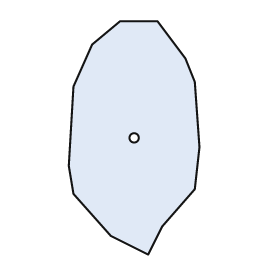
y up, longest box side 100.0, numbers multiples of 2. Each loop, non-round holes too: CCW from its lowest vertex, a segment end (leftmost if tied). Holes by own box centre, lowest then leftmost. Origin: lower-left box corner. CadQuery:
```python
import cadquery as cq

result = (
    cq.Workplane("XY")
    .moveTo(34.0, 0.0)
    .lineTo(40.0, 12.0)
    .lineTo(54.0, 28.0)
    .lineTo(56.0, 46.0)
    .lineTo(54.0, 74.0)
    .lineTo(50.0, 84.0)
    .lineTo(38.0, 100.0)
    .lineTo(22.0, 100.0)
    .lineTo(10.0, 90.0)
    .lineTo(2.0, 72.0)
    .lineTo(0.0, 38.0)
    .lineTo(2.0, 26.0)
    .lineTo(18.0, 8.0)
    .close()
    .moveTo(28.0, 50.0)
    .circle(2.0)
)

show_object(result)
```